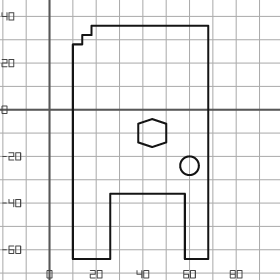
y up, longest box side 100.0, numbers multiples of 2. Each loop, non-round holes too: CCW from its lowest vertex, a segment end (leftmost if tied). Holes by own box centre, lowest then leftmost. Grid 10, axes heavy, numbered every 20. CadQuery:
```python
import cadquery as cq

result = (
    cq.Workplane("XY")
    .moveTo(10.0, -64.0)
    .lineTo(26.0, -64.0)
    .lineTo(26.0, -36.0)
    .lineTo(58.0, -36.0)
    .lineTo(58.0, -64.0)
    .lineTo(68.0, -64.0)
    .lineTo(68.0, 36.0)
    .lineTo(18.0, 36.0)
    .lineTo(18.0, 32.0)
    .lineTo(14.0, 32.0)
    .lineTo(14.0, 28.0)
    .lineTo(10.0, 28.0)
    .close()
    .moveTo(60.0, -24.0)
    .circle(4.0)
    .moveTo(44.0, -16.0)
    .lineTo(50.0, -14.0)
    .lineTo(50.0, -6.0)
    .lineTo(44.0, -4.0)
    .lineTo(38.0, -6.0)
    .lineTo(38.0, -14.0)
    .close()
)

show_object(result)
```